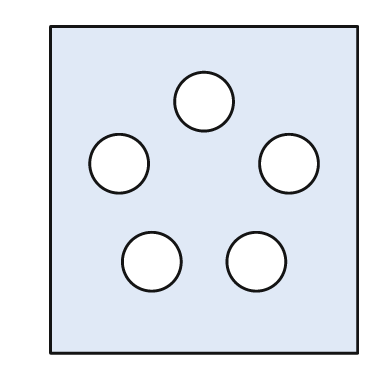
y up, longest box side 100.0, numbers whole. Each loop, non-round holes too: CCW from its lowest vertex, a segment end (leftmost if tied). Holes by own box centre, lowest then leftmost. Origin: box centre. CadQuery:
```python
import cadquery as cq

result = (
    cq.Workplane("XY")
    .moveTo(-47.0, -50.0)
    .lineTo(47.0, -50.0)
    .lineTo(47.0, 50.0)
    .lineTo(-47.0, 50.0)
    .close()
    .moveTo(-16.0, -22.0)
    .circle(9.0)
    .moveTo(16.0, -22.0)
    .circle(9.0)
    .moveTo(-26.0, 8.0)
    .circle(9.0)
    .moveTo(26.0, 8.0)
    .circle(9.0)
    .moveTo(0.0, 27.0)
    .circle(9.0)
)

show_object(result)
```